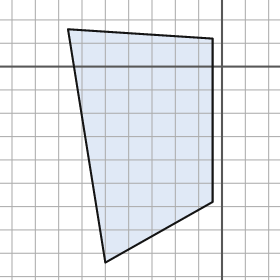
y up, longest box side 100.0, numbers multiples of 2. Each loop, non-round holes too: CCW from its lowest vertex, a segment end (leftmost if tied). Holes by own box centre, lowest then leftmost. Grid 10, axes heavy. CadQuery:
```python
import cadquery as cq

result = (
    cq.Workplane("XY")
    .moveTo(-50.0, -84.0)
    .lineTo(-4.0, -58.0)
    .lineTo(-4.0, 12.0)
    .lineTo(-66.0, 16.0)
    .close()
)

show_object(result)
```